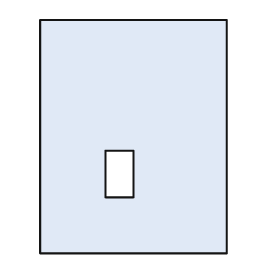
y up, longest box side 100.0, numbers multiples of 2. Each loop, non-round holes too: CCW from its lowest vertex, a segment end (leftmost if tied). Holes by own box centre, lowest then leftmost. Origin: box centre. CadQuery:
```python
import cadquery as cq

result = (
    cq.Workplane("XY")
    .moveTo(-40.0, -50.0)
    .lineTo(40.0, -50.0)
    .lineTo(40.0, 50.0)
    .lineTo(-40.0, 50.0)
    .close()
    .moveTo(-12.0, -26.0)
    .lineTo(0.0, -26.0)
    .lineTo(0.0, -6.0)
    .lineTo(-12.0, -6.0)
    .close()
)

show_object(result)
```